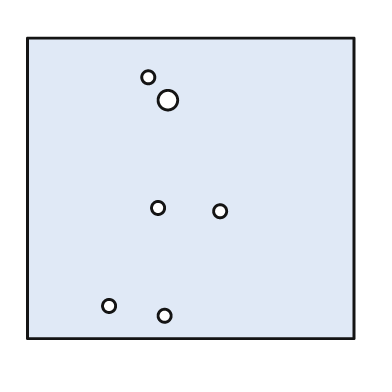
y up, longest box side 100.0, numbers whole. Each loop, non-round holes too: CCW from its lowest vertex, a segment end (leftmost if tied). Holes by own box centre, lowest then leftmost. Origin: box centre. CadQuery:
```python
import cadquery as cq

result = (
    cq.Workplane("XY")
    .moveTo(-50.0, -46.0)
    .lineTo(50.0, -46.0)
    .lineTo(50.0, 46.0)
    .lineTo(-50.0, 46.0)
    .close()
    .moveTo(-8.0, -39.0)
    .circle(2.0)
    .moveTo(-25.0, -36.0)
    .circle(2.0)
    .moveTo(9.0, -7.0)
    .circle(2.0)
    .moveTo(-10.0, -6.0)
    .circle(2.0)
    .moveTo(-7.0, 27.0)
    .circle(3.0)
    .moveTo(-13.0, 34.0)
    .circle(2.0)
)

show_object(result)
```